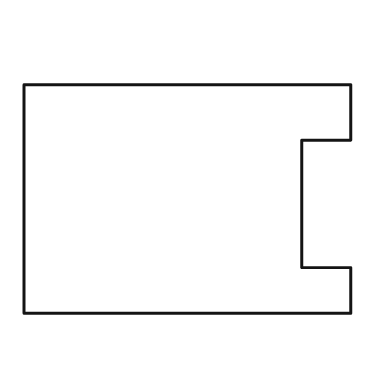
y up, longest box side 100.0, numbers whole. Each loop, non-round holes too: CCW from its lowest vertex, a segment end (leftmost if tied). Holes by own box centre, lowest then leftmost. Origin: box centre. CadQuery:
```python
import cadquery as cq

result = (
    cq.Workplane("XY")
    .moveTo(-50.0, -35.0)
    .lineTo(50.0, -35.0)
    .lineTo(50.0, -21.0)
    .lineTo(35.0, -21.0)
    .lineTo(35.0, 18.0)
    .lineTo(50.0, 18.0)
    .lineTo(50.0, 35.0)
    .lineTo(-50.0, 35.0)
    .close()
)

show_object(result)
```